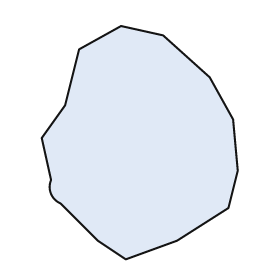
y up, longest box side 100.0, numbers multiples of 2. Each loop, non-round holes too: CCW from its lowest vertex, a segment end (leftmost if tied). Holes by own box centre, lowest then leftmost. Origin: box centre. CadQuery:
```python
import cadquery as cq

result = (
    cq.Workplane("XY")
    .moveTo(-6.0, -50.0)
    .lineTo(16.0, -42.0)
    .lineTo(38.0, -28.0)
    .lineTo(42.0, -12.0)
    .lineTo(40.0, 10.0)
    .lineTo(30.0, 28.0)
    .lineTo(10.0, 46.0)
    .lineTo(-8.0, 50.0)
    .lineTo(-26.0, 40.0)
    .lineTo(-32.0, 16.0)
    .lineTo(-42.0, 2.0)
    .lineTo(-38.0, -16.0)
    .threePointArc((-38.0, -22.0), (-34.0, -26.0))
    .lineTo(-18.0, -42.0)
    .close()
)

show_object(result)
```